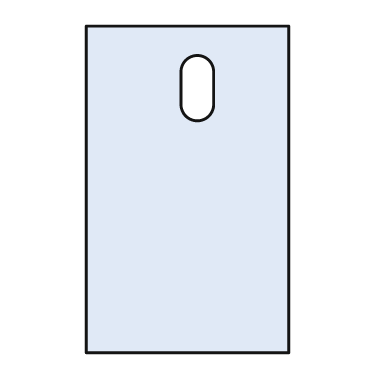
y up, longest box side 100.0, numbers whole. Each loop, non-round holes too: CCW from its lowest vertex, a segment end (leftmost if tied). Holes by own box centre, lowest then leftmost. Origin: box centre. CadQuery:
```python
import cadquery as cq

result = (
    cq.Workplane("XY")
    .moveTo(-31.0, -50.0)
    .lineTo(31.0, -50.0)
    .lineTo(31.0, 50.0)
    .lineTo(-31.0, 50.0)
    .close()
    .moveTo(-2.0, 26.0)
    .threePointArc((3.0, 21.0), (8.0, 26.0))
    .lineTo(8.0, 36.0)
    .threePointArc((3.0, 41.0), (-2.0, 36.0))
    .close()
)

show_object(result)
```